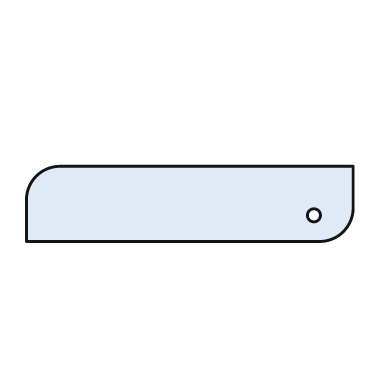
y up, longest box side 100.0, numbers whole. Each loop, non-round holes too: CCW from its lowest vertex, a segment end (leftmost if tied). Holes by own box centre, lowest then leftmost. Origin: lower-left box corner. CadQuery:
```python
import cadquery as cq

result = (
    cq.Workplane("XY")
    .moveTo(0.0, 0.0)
    .lineTo(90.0, 0.0)
    .threePointArc((97.0, 3.0), (100.0, 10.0))
    .lineTo(100.0, 23.0)
    .lineTo(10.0, 23.0)
    .threePointArc((3.0, 20.0), (0.0, 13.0))
    .close()
    .moveTo(88.0, 8.0)
    .circle(2.0)
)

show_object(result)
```